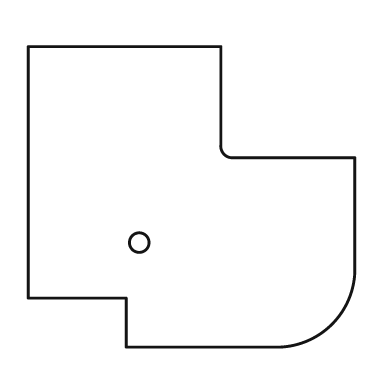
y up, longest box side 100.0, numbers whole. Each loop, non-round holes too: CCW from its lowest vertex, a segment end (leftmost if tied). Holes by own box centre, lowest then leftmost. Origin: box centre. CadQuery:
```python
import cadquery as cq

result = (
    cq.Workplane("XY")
    .moveTo(-20.0, -46.0)
    .lineTo(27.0, -46.0)
    .threePointArc((43.0, -39.0), (50.0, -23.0))
    .lineTo(50.0, 12.0)
    .lineTo(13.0, 12.0)
    .threePointArc((10.0, 13.0), (9.0, 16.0))
    .lineTo(9.0, 46.0)
    .lineTo(-50.0, 46.0)
    .lineTo(-50.0, -31.0)
    .lineTo(-20.0, -31.0)
    .close()
    .moveTo(-16.0, -14.0)
    .circle(3.0)
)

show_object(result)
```